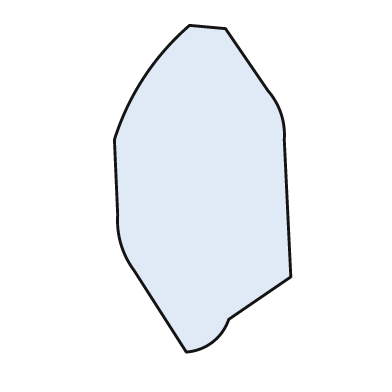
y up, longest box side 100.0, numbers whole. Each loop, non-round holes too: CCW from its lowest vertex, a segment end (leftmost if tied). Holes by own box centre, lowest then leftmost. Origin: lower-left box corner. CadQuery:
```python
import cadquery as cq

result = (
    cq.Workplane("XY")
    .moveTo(22.0, 0.0)
    .threePointArc((30.0, 3.0), (35.0, 10.0))
    .lineTo(54.0, 23.0)
    .lineTo(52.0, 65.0)
    .threePointArc((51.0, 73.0), (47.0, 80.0))
    .lineTo(34.0, 99.0)
    .lineTo(23.0, 100.0)
    .threePointArc((9.0, 84.0), (0.0, 65.0))
    .lineTo(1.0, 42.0)
    .threePointArc((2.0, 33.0), (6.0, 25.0))
    .close()
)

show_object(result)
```